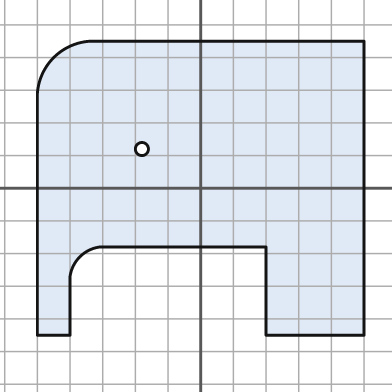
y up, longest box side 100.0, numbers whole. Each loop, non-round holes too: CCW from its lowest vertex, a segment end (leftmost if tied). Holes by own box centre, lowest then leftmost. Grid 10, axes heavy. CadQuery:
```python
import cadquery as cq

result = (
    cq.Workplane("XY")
    .moveTo(-50.0, -45.0)
    .lineTo(-40.0, -45.0)
    .lineTo(-40.0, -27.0)
    .threePointArc((-37.0, -21.0), (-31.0, -18.0))
    .lineTo(20.0, -18.0)
    .lineTo(20.0, -45.0)
    .lineTo(50.0, -45.0)
    .lineTo(50.0, 45.0)
    .lineTo(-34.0, 45.0)
    .threePointArc((-45.0, 40.0), (-50.0, 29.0))
    .close()
    .moveTo(-18.0, 12.0)
    .circle(2.0)
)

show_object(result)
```